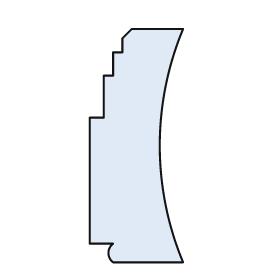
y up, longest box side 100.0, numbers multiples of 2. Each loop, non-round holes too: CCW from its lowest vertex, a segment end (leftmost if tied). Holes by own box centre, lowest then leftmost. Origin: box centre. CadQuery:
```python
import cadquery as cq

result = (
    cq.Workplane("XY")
    .moveTo(-10.0, -50.0)
    .lineTo(20.0, -50.0)
    .threePointArc((10.0, 0.0), (20.0, 50.0))
    .lineTo(-2.0, 50.0)
    .lineTo(-6.0, 46.0)
    .lineTo(-6.0, 40.0)
    .lineTo(-10.0, 40.0)
    .lineTo(-10.0, 30.0)
    .lineTo(-14.0, 30.0)
    .lineTo(-14.0, 12.0)
    .lineTo(-20.0, 12.0)
    .lineTo(-20.0, -42.0)
    .lineTo(-10.0, -42.0)
    .threePointArc((-12.0, -46.0), (-10.0, -50.0))
    .close()
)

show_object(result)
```